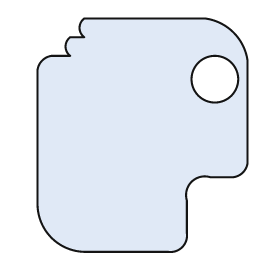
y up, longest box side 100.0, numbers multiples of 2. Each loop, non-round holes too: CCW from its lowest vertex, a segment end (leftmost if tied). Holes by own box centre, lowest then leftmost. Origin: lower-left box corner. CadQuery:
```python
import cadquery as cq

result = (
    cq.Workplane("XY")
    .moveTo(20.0, 0.0)
    .lineTo(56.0, 0.0)
    .threePointArc((62.0, 2.0), (64.0, 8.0))
    .lineTo(64.0, 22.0)
    .threePointArc((66.0, 30.0), (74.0, 32.0))
    .lineTo(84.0, 32.0)
    .threePointArc((88.0, 34.0), (90.0, 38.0))
    .lineTo(90.0, 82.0)
    .threePointArc((84.0, 94.0), (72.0, 100.0))
    .lineTo(20.0, 100.0)
    .threePointArc((18.0, 96.0), (20.0, 92.0))
    .lineTo(14.0, 92.0)
    .threePointArc((12.0, 88.0), (14.0, 84.0))
    .lineTo(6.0, 84.0)
    .threePointArc((2.0, 82.0), (0.0, 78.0))
    .lineTo(0.0, 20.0)
    .threePointArc((6.0, 6.0), (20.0, 0.0))
    .close()
    .moveTo(76.0, 74.0)
    .circle(10.0)
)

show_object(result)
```